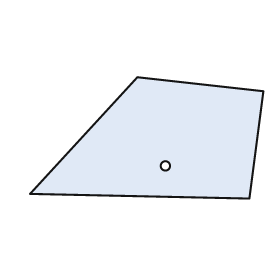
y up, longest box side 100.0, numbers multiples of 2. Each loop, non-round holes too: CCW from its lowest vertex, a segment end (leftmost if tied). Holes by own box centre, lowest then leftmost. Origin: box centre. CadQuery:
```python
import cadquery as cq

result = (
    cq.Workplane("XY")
    .moveTo(44.0, -26.0)
    .lineTo(50.0, 20.0)
    .lineTo(-4.0, 26.0)
    .lineTo(-50.0, -24.0)
    .close()
    .moveTo(8.0, -12.0)
    .circle(2.0)
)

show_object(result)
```